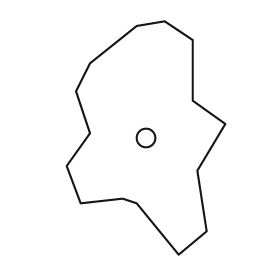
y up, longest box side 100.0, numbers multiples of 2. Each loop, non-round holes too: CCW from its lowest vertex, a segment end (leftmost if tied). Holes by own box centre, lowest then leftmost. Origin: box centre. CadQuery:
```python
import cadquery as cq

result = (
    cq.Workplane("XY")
    .moveTo(14.0, -50.0)
    .lineTo(26.0, -40.0)
    .lineTo(22.0, -14.0)
    .lineTo(34.0, 6.0)
    .lineTo(20.0, 16.0)
    .lineTo(20.0, 42.0)
    .lineTo(8.0, 50.0)
    .lineTo(-4.0, 48.0)
    .lineTo(-24.0, 32.0)
    .lineTo(-30.0, 20.0)
    .lineTo(-24.0, 2.0)
    .lineTo(-34.0, -12.0)
    .lineTo(-28.0, -28.0)
    .lineTo(-10.0, -26.0)
    .lineTo(-4.0, -28.0)
    .close()
    .moveTo(0.0, 0.0)
    .circle(4.0)
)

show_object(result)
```